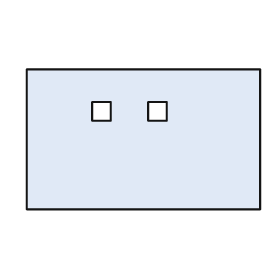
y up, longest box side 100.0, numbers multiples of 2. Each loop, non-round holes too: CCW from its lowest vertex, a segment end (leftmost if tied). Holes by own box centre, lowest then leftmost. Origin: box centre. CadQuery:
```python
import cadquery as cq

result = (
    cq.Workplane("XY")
    .moveTo(-50.0, -30.0)
    .lineTo(50.0, -30.0)
    .lineTo(50.0, 30.0)
    .lineTo(-50.0, 30.0)
    .close()
    .moveTo(-22.0, 8.0)
    .lineTo(-14.0, 8.0)
    .lineTo(-14.0, 16.0)
    .lineTo(-22.0, 16.0)
    .close()
    .moveTo(2.0, 8.0)
    .lineTo(10.0, 8.0)
    .lineTo(10.0, 16.0)
    .lineTo(2.0, 16.0)
    .close()
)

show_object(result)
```